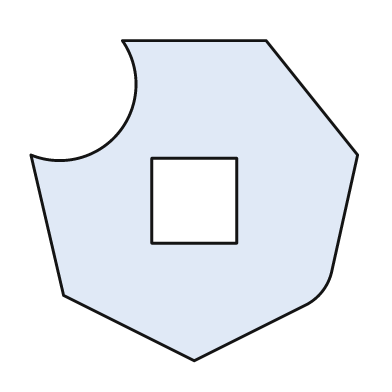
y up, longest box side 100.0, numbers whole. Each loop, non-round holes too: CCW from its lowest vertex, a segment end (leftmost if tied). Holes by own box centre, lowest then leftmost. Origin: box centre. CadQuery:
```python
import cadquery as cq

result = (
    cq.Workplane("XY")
    .moveTo(0.0, -49.0)
    .lineTo(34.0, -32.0)
    .threePointArc((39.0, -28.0), (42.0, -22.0))
    .lineTo(50.0, 14.0)
    .lineTo(22.0, 49.0)
    .lineTo(-22.0, 49.0)
    .threePointArc((-23.0, 21.0), (-50.0, 14.0))
    .lineTo(-40.0, -29.0)
    .close()
    .moveTo(-13.0, -13.0)
    .lineTo(13.0, -13.0)
    .lineTo(13.0, 13.0)
    .lineTo(-13.0, 13.0)
    .close()
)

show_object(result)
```